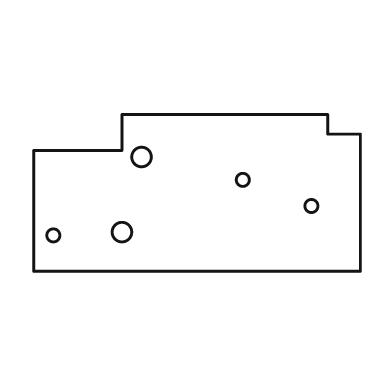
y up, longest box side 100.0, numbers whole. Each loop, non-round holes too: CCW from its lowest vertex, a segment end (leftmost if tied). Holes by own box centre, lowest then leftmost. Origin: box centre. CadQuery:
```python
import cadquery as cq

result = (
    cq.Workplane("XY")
    .moveTo(-50.0, -24.0)
    .lineTo(50.0, -24.0)
    .lineTo(50.0, 18.0)
    .lineTo(40.0, 18.0)
    .lineTo(40.0, 24.0)
    .lineTo(-23.0, 24.0)
    .lineTo(-23.0, 13.0)
    .lineTo(-50.0, 13.0)
    .close()
    .moveTo(-44.0, -13.0)
    .circle(2.0)
    .moveTo(-23.0, -12.0)
    .circle(3.0)
    .moveTo(35.0, -4.0)
    .circle(2.0)
    .moveTo(14.0, 4.0)
    .circle(2.0)
    .moveTo(-17.0, 11.0)
    .circle(3.0)
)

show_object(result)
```